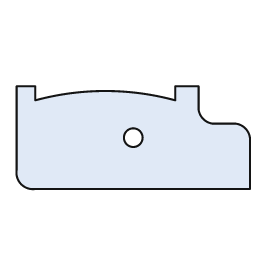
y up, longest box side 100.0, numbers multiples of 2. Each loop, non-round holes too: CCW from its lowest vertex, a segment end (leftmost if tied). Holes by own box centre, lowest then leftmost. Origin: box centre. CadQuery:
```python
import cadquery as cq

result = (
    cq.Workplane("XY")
    .moveTo(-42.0, -22.0)
    .lineTo(50.0, -22.0)
    .lineTo(50.0, 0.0)
    .threePointArc((48.0, 4.0), (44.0, 6.0))
    .lineTo(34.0, 6.0)
    .threePointArc((30.0, 8.0), (28.0, 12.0))
    .lineTo(28.0, 22.0)
    .lineTo(18.0, 22.0)
    .lineTo(18.0, 16.0)
    .threePointArc((-12.0, 20.0), (-42.0, 16.0))
    .lineTo(-42.0, 22.0)
    .lineTo(-50.0, 22.0)
    .lineTo(-50.0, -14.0)
    .threePointArc((-48.0, -20.0), (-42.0, -22.0))
    .close()
    .moveTo(0.0, 0.0)
    .circle(4.0)
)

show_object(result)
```